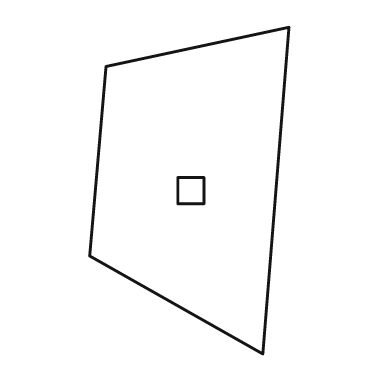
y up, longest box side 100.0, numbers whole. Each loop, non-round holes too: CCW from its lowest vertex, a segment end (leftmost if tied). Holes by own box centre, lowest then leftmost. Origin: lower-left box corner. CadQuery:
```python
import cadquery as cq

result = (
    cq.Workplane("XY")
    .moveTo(53.0, 0.0)
    .lineTo(61.0, 100.0)
    .lineTo(5.0, 88.0)
    .lineTo(0.0, 30.0)
    .close()
    .moveTo(27.0, 46.0)
    .lineTo(35.0, 46.0)
    .lineTo(35.0, 54.0)
    .lineTo(27.0, 54.0)
    .close()
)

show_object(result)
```